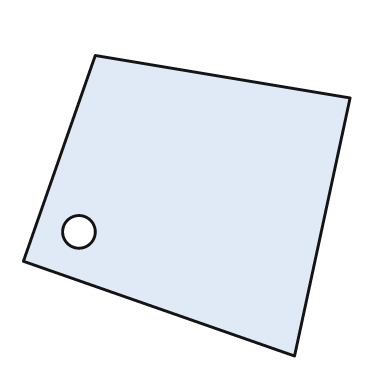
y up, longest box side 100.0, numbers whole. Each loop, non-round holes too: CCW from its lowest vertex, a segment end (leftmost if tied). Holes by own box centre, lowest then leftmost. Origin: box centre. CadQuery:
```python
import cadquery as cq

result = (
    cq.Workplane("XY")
    .moveTo(33.0, -46.0)
    .lineTo(50.0, 33.0)
    .lineTo(-28.0, 46.0)
    .lineTo(-50.0, -17.0)
    .close()
    .moveTo(-33.0, -8.0)
    .circle(5.0)
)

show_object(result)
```